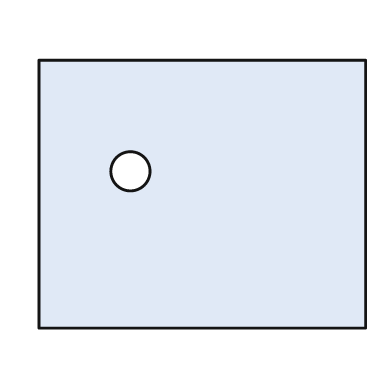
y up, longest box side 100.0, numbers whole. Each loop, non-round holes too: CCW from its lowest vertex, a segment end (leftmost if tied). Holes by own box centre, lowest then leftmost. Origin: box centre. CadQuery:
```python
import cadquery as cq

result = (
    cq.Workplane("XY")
    .moveTo(-50.0, -41.0)
    .lineTo(50.0, -41.0)
    .lineTo(50.0, 41.0)
    .lineTo(-50.0, 41.0)
    .close()
    .moveTo(-22.0, 7.0)
    .circle(6.0)
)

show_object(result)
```